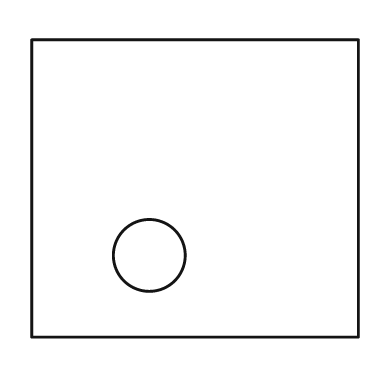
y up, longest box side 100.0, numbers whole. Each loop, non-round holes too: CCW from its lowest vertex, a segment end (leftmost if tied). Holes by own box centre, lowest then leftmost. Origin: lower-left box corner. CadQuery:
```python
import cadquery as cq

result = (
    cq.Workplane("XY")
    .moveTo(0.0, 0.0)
    .lineTo(100.0, 0.0)
    .lineTo(100.0, 91.0)
    .lineTo(0.0, 91.0)
    .close()
    .moveTo(36.0, 25.0)
    .circle(11.0)
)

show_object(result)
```